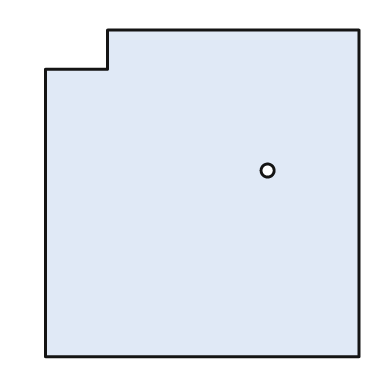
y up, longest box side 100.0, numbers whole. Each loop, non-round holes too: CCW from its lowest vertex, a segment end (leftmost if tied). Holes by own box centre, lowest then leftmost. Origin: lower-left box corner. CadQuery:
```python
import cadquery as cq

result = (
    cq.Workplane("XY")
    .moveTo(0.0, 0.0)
    .lineTo(96.0, 0.0)
    .lineTo(96.0, 100.0)
    .lineTo(19.0, 100.0)
    .lineTo(19.0, 88.0)
    .lineTo(0.0, 88.0)
    .close()
    .moveTo(68.0, 57.0)
    .circle(2.0)
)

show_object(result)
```